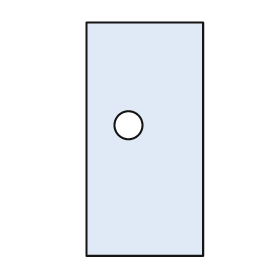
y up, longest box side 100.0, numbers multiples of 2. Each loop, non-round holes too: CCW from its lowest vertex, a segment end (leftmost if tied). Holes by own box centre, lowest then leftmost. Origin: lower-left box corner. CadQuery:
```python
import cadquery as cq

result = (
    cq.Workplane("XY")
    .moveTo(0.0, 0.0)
    .lineTo(50.0, 0.0)
    .lineTo(50.0, 100.0)
    .lineTo(0.0, 100.0)
    .close()
    .moveTo(18.0, 56.0)
    .circle(6.0)
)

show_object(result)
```